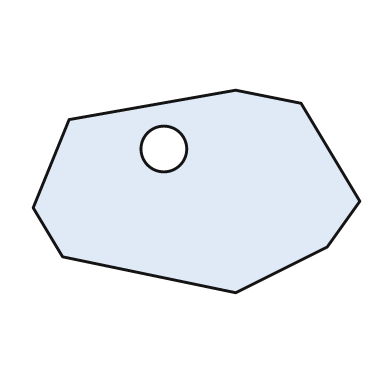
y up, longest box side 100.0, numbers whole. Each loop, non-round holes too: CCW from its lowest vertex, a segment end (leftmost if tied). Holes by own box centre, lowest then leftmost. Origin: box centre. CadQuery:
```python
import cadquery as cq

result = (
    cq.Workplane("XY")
    .moveTo(12.0, -31.0)
    .lineTo(40.0, -17.0)
    .lineTo(50.0, -3.0)
    .lineTo(32.0, 27.0)
    .lineTo(12.0, 31.0)
    .lineTo(-39.0, 22.0)
    .lineTo(-50.0, -5.0)
    .lineTo(-41.0, -20.0)
    .close()
    .moveTo(-10.0, 13.0)
    .circle(7.0)
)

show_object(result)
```